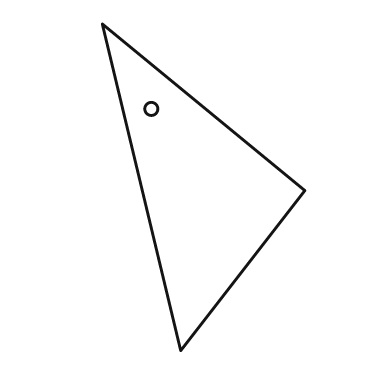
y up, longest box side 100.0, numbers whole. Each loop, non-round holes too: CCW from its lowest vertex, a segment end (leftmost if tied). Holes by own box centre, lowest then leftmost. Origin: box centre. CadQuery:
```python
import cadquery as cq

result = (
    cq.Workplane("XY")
    .moveTo(-7.0, -50.0)
    .lineTo(31.0, -1.0)
    .lineTo(-31.0, 50.0)
    .close()
    .moveTo(-16.0, 24.0)
    .circle(2.0)
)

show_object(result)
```